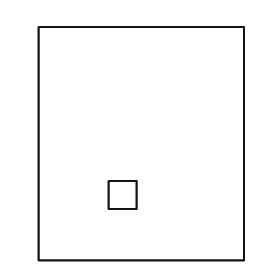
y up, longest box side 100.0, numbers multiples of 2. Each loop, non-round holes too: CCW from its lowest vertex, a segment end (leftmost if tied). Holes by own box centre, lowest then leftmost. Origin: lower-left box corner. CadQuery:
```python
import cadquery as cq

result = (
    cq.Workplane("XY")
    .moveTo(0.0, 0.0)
    .lineTo(88.0, 0.0)
    .lineTo(88.0, 100.0)
    .lineTo(0.0, 100.0)
    .close()
    .moveTo(30.0, 22.0)
    .lineTo(42.0, 22.0)
    .lineTo(42.0, 34.0)
    .lineTo(30.0, 34.0)
    .close()
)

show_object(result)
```